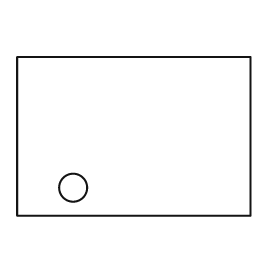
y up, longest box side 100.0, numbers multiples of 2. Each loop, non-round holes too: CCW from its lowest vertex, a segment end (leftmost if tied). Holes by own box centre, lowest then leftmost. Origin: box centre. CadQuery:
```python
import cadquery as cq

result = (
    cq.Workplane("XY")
    .moveTo(-50.0, -34.0)
    .lineTo(50.0, -34.0)
    .lineTo(50.0, 34.0)
    .lineTo(-50.0, 34.0)
    .close()
    .moveTo(-26.0, -22.0)
    .circle(6.0)
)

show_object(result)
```